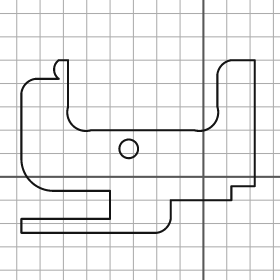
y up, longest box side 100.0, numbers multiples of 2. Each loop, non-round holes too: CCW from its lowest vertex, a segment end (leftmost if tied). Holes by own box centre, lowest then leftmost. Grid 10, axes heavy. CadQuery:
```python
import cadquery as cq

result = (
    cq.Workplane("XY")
    .moveTo(-78.0, -24.0)
    .lineTo(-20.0, -24.0)
    .threePointArc((-16.0, -22.0), (-14.0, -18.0))
    .lineTo(-14.0, -10.0)
    .lineTo(12.0, -10.0)
    .lineTo(12.0, -4.0)
    .lineTo(22.0, -4.0)
    .lineTo(22.0, 50.0)
    .lineTo(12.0, 50.0)
    .threePointArc((8.0, 48.0), (6.0, 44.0))
    .lineTo(6.0, 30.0)
    .threePointArc((4.0, 22.0), (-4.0, 20.0))
    .lineTo(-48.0, 20.0)
    .threePointArc((-56.0, 22.0), (-58.0, 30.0))
    .lineTo(-58.0, 50.0)
    .lineTo(-62.0, 50.0)
    .threePointArc((-64.0, 46.0), (-62.0, 42.0))
    .lineTo(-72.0, 42.0)
    .threePointArc((-76.0, 40.0), (-78.0, 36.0))
    .lineTo(-78.0, 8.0)
    .threePointArc((-74.0, -2.0), (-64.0, -6.0))
    .lineTo(-40.0, -6.0)
    .lineTo(-40.0, -18.0)
    .lineTo(-78.0, -18.0)
    .close()
    .moveTo(-32.0, 12.0)
    .circle(4.0)
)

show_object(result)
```